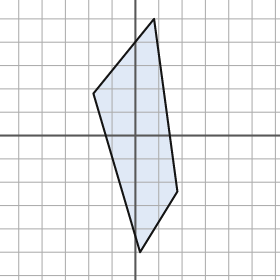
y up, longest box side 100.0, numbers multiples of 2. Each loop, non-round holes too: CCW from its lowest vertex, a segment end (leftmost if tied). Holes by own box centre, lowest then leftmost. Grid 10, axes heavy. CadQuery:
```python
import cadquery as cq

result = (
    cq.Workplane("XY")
    .moveTo(2.0, -50.0)
    .lineTo(18.0, -24.0)
    .lineTo(8.0, 50.0)
    .lineTo(-18.0, 18.0)
    .close()
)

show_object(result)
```